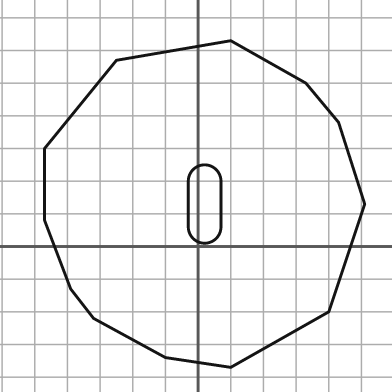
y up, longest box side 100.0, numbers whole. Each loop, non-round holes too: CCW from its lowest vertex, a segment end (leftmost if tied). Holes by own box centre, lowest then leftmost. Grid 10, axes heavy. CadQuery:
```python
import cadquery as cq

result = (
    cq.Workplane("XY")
    .moveTo(10.0, -37.0)
    .lineTo(40.0, -20.0)
    .lineTo(51.0, 13.0)
    .lineTo(43.0, 38.0)
    .lineTo(33.0, 50.0)
    .lineTo(10.0, 63.0)
    .lineTo(-25.0, 57.0)
    .lineTo(-47.0, 30.0)
    .lineTo(-47.0, 8.0)
    .lineTo(-39.0, -13.0)
    .lineTo(-32.0, -22.0)
    .lineTo(-10.0, -34.0)
    .close()
    .moveTo(-3.0, 6.0)
    .threePointArc((2.0, 1.0), (7.0, 6.0))
    .lineTo(7.0, 20.0)
    .threePointArc((2.0, 25.0), (-3.0, 20.0))
    .close()
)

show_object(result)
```